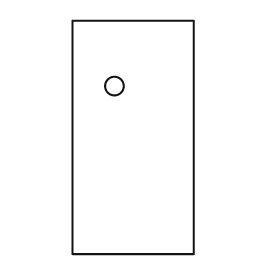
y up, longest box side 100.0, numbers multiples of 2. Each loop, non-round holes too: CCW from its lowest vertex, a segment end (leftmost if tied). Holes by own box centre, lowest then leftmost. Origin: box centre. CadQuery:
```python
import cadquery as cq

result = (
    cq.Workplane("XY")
    .moveTo(-26.0, -50.0)
    .lineTo(26.0, -50.0)
    .lineTo(26.0, 50.0)
    .lineTo(-26.0, 50.0)
    .close()
    .moveTo(-8.0, 22.0)
    .circle(4.0)
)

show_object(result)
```